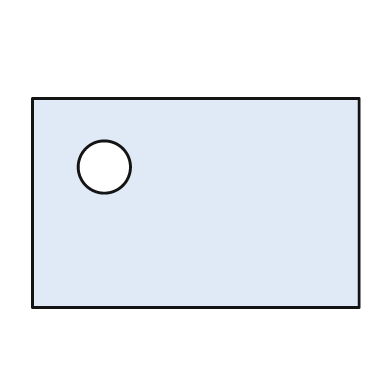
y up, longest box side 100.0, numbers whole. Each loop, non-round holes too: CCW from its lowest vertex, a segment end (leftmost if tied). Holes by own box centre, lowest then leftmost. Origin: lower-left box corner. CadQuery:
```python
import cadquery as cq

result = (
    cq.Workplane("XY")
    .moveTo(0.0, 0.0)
    .lineTo(100.0, 0.0)
    .lineTo(100.0, 64.0)
    .lineTo(0.0, 64.0)
    .close()
    .moveTo(22.0, 43.0)
    .circle(8.0)
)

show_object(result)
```